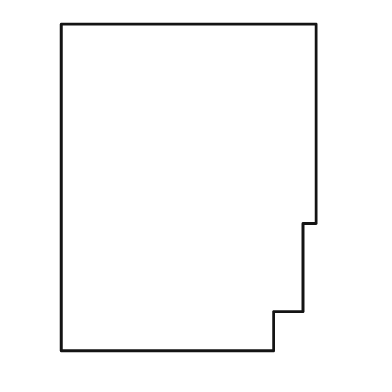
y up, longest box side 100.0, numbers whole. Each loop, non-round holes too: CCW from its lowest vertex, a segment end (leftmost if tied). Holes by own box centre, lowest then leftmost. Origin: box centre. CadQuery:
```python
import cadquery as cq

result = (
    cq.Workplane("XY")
    .moveTo(-39.0, -50.0)
    .lineTo(26.0, -50.0)
    .lineTo(26.0, -38.0)
    .lineTo(35.0, -38.0)
    .lineTo(35.0, -11.0)
    .lineTo(39.0, -11.0)
    .lineTo(39.0, 50.0)
    .lineTo(-39.0, 50.0)
    .close()
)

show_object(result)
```